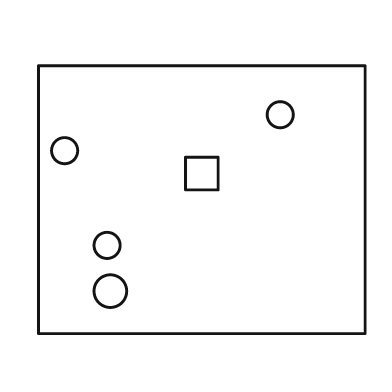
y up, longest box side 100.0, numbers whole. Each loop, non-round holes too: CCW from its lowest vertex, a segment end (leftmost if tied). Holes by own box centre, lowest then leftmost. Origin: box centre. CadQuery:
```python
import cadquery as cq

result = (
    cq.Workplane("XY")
    .moveTo(-50.0, -41.0)
    .lineTo(50.0, -41.0)
    .lineTo(50.0, 41.0)
    .lineTo(-50.0, 41.0)
    .close()
    .moveTo(-28.0, -28.0)
    .circle(5.0)
    .moveTo(-29.0, -14.0)
    .circle(4.0)
    .moveTo(-5.0, 3.0)
    .lineTo(5.0, 3.0)
    .lineTo(5.0, 13.0)
    .lineTo(-5.0, 13.0)
    .close()
    .moveTo(-42.0, 15.0)
    .circle(4.0)
    .moveTo(24.0, 26.0)
    .circle(4.0)
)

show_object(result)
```